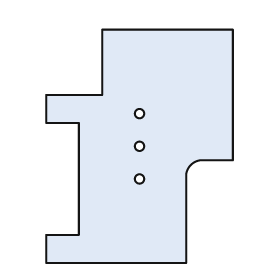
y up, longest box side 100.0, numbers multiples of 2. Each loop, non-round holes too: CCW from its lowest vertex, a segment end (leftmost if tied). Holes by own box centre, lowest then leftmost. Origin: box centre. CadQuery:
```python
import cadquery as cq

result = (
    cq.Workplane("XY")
    .moveTo(-40.0, -50.0)
    .lineTo(20.0, -50.0)
    .lineTo(20.0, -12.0)
    .threePointArc((22.0, -8.0), (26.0, -6.0))
    .lineTo(40.0, -6.0)
    .lineTo(40.0, 50.0)
    .lineTo(-16.0, 50.0)
    .lineTo(-16.0, 22.0)
    .lineTo(-40.0, 22.0)
    .lineTo(-40.0, 10.0)
    .lineTo(-26.0, 10.0)
    .lineTo(-26.0, -38.0)
    .lineTo(-40.0, -38.0)
    .close()
    .moveTo(0.0, -14.0)
    .circle(2.0)
    .moveTo(0.0, 0.0)
    .circle(2.0)
    .moveTo(0.0, 14.0)
    .circle(2.0)
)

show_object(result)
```